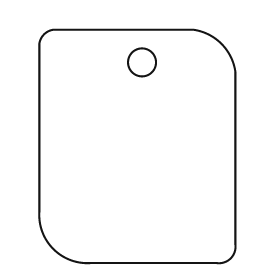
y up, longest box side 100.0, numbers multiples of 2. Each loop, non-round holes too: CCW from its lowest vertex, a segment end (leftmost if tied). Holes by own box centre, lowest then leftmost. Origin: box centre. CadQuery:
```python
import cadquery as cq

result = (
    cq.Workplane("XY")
    .moveTo(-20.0, -50.0)
    .lineTo(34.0, -50.0)
    .threePointArc((40.0, -48.0), (42.0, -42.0))
    .lineTo(42.0, 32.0)
    .threePointArc((36.0, 44.0), (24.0, 50.0))
    .lineTo(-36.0, 50.0)
    .threePointArc((-40.0, 48.0), (-42.0, 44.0))
    .lineTo(-42.0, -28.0)
    .threePointArc((-36.0, -44.0), (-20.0, -50.0))
    .close()
    .moveTo(2.0, 36.0)
    .circle(6.0)
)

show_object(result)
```